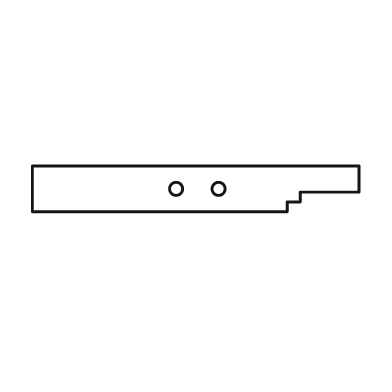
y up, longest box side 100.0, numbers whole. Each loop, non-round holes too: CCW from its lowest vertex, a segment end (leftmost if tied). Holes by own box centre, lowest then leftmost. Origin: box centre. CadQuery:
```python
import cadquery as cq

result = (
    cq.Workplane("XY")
    .moveTo(-50.0, -7.0)
    .lineTo(28.0, -7.0)
    .lineTo(28.0, -4.0)
    .lineTo(32.0, -4.0)
    .lineTo(32.0, -1.0)
    .lineTo(50.0, -1.0)
    .lineTo(50.0, 7.0)
    .lineTo(-50.0, 7.0)
    .close()
    .moveTo(-6.0, 0.0)
    .circle(2.0)
    .moveTo(7.0, 0.0)
    .circle(2.0)
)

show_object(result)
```